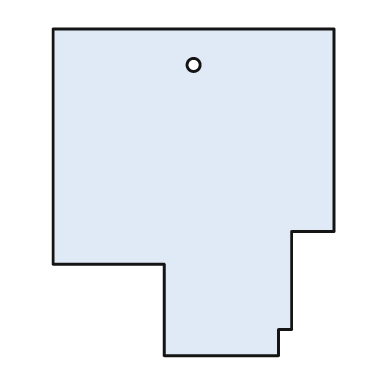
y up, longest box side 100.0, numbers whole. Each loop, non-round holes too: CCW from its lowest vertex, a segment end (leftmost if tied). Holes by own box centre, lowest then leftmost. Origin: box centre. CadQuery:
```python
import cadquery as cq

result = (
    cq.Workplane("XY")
    .moveTo(-9.0, -50.0)
    .lineTo(26.0, -50.0)
    .lineTo(26.0, -42.0)
    .lineTo(30.0, -42.0)
    .lineTo(30.0, -12.0)
    .lineTo(43.0, -12.0)
    .lineTo(43.0, 50.0)
    .lineTo(-43.0, 50.0)
    .lineTo(-43.0, -22.0)
    .lineTo(-9.0, -22.0)
    .close()
    .moveTo(0.0, 39.0)
    .circle(2.0)
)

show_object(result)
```